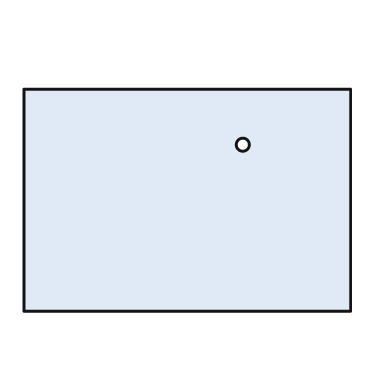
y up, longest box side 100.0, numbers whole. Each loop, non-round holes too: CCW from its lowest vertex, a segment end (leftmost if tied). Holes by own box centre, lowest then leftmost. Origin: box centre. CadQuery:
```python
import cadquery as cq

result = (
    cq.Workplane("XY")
    .moveTo(-50.0, -34.0)
    .lineTo(50.0, -34.0)
    .lineTo(50.0, 34.0)
    .lineTo(-50.0, 34.0)
    .close()
    .moveTo(17.0, 17.0)
    .circle(2.0)
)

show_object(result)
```